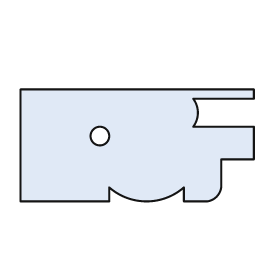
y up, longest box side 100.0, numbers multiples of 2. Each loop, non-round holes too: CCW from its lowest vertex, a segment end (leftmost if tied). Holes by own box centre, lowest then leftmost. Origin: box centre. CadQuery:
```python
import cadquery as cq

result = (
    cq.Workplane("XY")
    .moveTo(-50.0, -24.0)
    .lineTo(-12.0, -24.0)
    .lineTo(-12.0, -18.0)
    .threePointArc((4.0, -24.0), (20.0, -18.0))
    .lineTo(20.0, -24.0)
    .lineTo(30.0, -24.0)
    .threePointArc((34.0, -22.0), (36.0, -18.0))
    .lineTo(36.0, -6.0)
    .lineTo(50.0, -6.0)
    .lineTo(50.0, 8.0)
    .lineTo(24.0, 8.0)
    .threePointArc((26.0, 14.0), (24.0, 20.0))
    .lineTo(50.0, 20.0)
    .lineTo(50.0, 24.0)
    .lineTo(-50.0, 24.0)
    .close()
    .moveTo(-16.0, 4.0)
    .circle(4.0)
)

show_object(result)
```